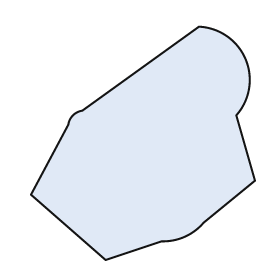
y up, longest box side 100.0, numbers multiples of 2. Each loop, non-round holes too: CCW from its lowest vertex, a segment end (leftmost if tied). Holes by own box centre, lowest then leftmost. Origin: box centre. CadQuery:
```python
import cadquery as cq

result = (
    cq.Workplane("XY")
    .moveTo(-16.0, -50.0)
    .lineTo(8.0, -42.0)
    .threePointArc((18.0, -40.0), (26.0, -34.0))
    .lineTo(48.0, -16.0)
    .lineTo(40.0, 12.0)
    .threePointArc((44.0, 36.0), (24.0, 50.0))
    .lineTo(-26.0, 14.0)
    .threePointArc((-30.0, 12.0), (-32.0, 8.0))
    .lineTo(-48.0, -22.0)
    .close()
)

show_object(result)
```